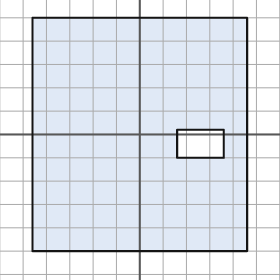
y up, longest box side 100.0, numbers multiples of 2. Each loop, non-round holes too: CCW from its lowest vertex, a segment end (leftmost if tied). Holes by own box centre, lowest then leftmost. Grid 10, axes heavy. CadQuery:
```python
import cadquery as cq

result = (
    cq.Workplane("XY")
    .moveTo(-46.0, -50.0)
    .lineTo(46.0, -50.0)
    .lineTo(46.0, 50.0)
    .lineTo(-46.0, 50.0)
    .close()
    .moveTo(16.0, -10.0)
    .lineTo(36.0, -10.0)
    .lineTo(36.0, 2.0)
    .lineTo(16.0, 2.0)
    .close()
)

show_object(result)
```